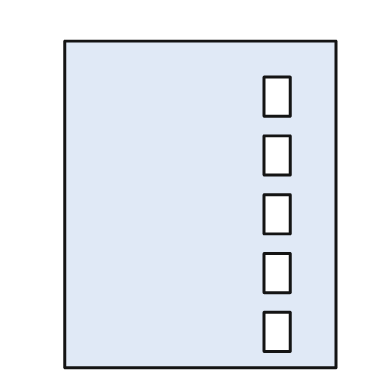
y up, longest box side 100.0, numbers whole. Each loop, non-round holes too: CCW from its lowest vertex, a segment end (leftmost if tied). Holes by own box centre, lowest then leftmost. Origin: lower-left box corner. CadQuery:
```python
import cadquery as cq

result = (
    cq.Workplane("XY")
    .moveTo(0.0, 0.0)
    .lineTo(83.0, 0.0)
    .lineTo(83.0, 100.0)
    .lineTo(0.0, 100.0)
    .close()
    .moveTo(61.0, 5.0)
    .lineTo(69.0, 5.0)
    .lineTo(69.0, 17.0)
    .lineTo(61.0, 17.0)
    .close()
    .moveTo(61.0, 23.0)
    .lineTo(69.0, 23.0)
    .lineTo(69.0, 35.0)
    .lineTo(61.0, 35.0)
    .close()
    .moveTo(61.0, 41.0)
    .lineTo(69.0, 41.0)
    .lineTo(69.0, 53.0)
    .lineTo(61.0, 53.0)
    .close()
    .moveTo(61.0, 59.0)
    .lineTo(69.0, 59.0)
    .lineTo(69.0, 71.0)
    .lineTo(61.0, 71.0)
    .close()
    .moveTo(61.0, 77.0)
    .lineTo(69.0, 77.0)
    .lineTo(69.0, 89.0)
    .lineTo(61.0, 89.0)
    .close()
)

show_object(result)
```